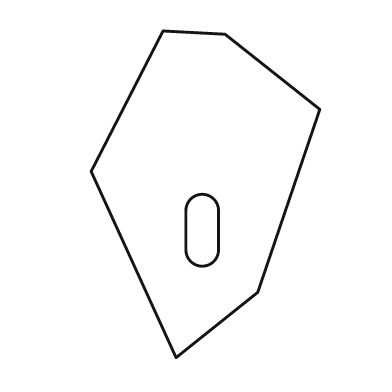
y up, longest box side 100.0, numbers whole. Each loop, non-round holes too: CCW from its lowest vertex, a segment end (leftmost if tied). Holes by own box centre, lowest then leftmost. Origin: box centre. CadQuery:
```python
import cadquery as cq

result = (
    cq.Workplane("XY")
    .moveTo(-9.0, -50.0)
    .lineTo(16.0, -30.0)
    .lineTo(35.0, 26.0)
    .lineTo(6.0, 49.0)
    .lineTo(-13.0, 50.0)
    .lineTo(-35.0, 7.0)
    .close()
    .moveTo(-6.0, -17.0)
    .threePointArc((-1.0, -22.0), (4.0, -17.0))
    .lineTo(4.0, -5.0)
    .threePointArc((-1.0, 0.0), (-6.0, -5.0))
    .close()
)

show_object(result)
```